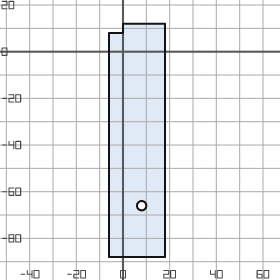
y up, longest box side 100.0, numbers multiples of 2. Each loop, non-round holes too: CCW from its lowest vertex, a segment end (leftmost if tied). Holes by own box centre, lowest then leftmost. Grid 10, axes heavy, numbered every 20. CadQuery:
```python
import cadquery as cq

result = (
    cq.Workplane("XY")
    .moveTo(-6.0, -88.0)
    .lineTo(18.0, -88.0)
    .lineTo(18.0, 12.0)
    .lineTo(0.0, 12.0)
    .lineTo(0.0, 8.0)
    .lineTo(-6.0, 8.0)
    .close()
    .moveTo(8.0, -66.0)
    .circle(2.0)
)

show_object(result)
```